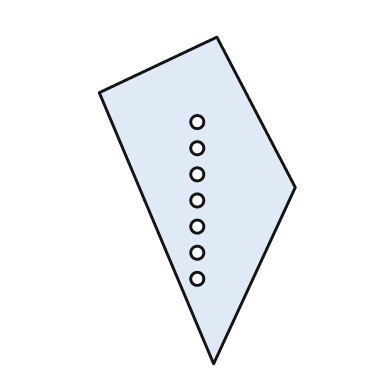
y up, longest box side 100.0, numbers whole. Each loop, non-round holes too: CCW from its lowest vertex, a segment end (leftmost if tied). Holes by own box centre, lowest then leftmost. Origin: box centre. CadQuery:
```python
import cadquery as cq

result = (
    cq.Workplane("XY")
    .moveTo(5.0, -50.0)
    .lineTo(30.0, 4.0)
    .lineTo(6.0, 50.0)
    .lineTo(-30.0, 33.0)
    .close()
    .moveTo(0.0, -24.0)
    .circle(2.0)
    .moveTo(0.0, -16.0)
    .circle(2.0)
    .moveTo(0.0, -8.0)
    .circle(2.0)
    .moveTo(0.0, 0.0)
    .circle(2.0)
    .moveTo(0.0, 8.0)
    .circle(2.0)
    .moveTo(0.0, 16.0)
    .circle(2.0)
    .moveTo(0.0, 24.0)
    .circle(2.0)
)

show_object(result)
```